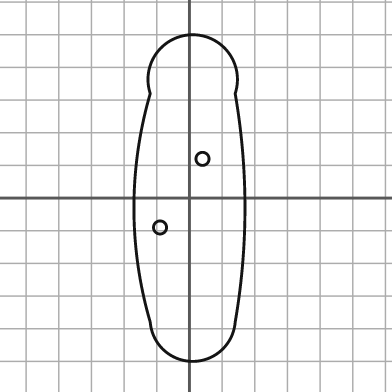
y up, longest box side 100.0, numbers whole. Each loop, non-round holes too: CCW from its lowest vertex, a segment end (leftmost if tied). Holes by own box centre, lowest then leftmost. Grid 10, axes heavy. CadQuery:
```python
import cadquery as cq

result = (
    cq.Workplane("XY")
    .moveTo(-12.0, -38.0)
    .threePointArc((1.0, -50.0), (14.0, -38.0))
    .threePointArc((17.0, -3.0), (14.0, 32.0))
    .threePointArc((1.0, 50.0), (-12.0, 32.0))
    .threePointArc((-17.0, -3.0), (-12.0, -38.0))
    .close()
    .moveTo(-9.0, -9.0)
    .circle(2.0)
    .moveTo(4.0, 12.0)
    .circle(2.0)
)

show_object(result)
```